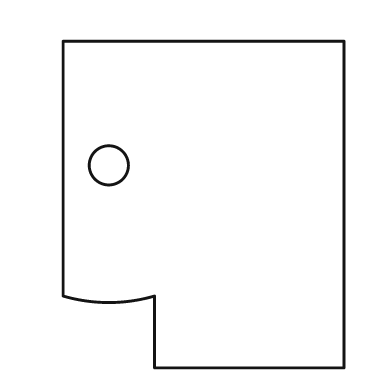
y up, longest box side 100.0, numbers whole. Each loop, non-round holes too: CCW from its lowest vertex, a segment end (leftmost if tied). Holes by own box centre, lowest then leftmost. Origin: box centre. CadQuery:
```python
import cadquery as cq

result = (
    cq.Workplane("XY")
    .moveTo(-15.0, -50.0)
    .lineTo(43.0, -50.0)
    .lineTo(43.0, 50.0)
    .lineTo(-43.0, 50.0)
    .lineTo(-43.0, -28.0)
    .threePointArc((-29.0, -30.0), (-15.0, -28.0))
    .close()
    .moveTo(-29.0, 12.0)
    .circle(6.0)
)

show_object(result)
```